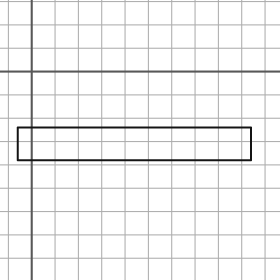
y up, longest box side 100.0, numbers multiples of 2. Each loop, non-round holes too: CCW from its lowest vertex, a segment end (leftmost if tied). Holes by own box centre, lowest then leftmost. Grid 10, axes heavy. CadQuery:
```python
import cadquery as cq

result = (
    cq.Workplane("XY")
    .moveTo(-6.0, -38.0)
    .lineTo(94.0, -38.0)
    .lineTo(94.0, -24.0)
    .lineTo(-6.0, -24.0)
    .close()
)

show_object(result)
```